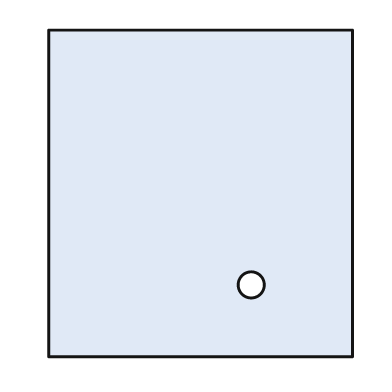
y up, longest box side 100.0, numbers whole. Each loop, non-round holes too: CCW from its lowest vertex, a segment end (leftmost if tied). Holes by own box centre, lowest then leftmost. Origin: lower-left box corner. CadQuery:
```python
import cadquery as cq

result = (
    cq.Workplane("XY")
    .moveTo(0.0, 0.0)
    .lineTo(93.0, 0.0)
    .lineTo(93.0, 100.0)
    .lineTo(0.0, 100.0)
    .close()
    .moveTo(62.0, 22.0)
    .circle(4.0)
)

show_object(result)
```